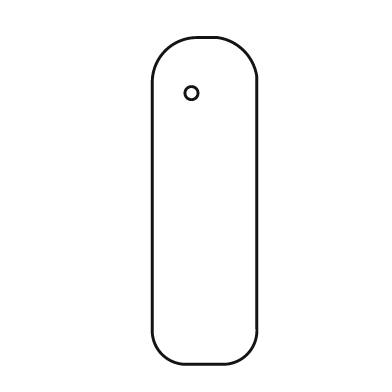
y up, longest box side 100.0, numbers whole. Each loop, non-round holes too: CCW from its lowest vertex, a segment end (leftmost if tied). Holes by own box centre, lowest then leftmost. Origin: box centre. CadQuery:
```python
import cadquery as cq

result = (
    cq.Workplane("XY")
    .moveTo(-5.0, -50.0)
    .lineTo(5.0, -50.0)
    .threePointArc((13.0, -47.0), (16.0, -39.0))
    .lineTo(16.0, 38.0)
    .threePointArc((12.0, 46.0), (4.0, 50.0))
    .lineTo(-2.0, 50.0)
    .threePointArc((-12.0, 46.0), (-16.0, 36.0))
    .lineTo(-16.0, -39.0)
    .threePointArc((-13.0, -47.0), (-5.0, -50.0))
    .close()
    .moveTo(-4.0, 33.0)
    .circle(2.0)
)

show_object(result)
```